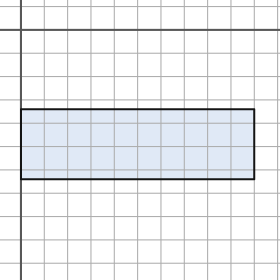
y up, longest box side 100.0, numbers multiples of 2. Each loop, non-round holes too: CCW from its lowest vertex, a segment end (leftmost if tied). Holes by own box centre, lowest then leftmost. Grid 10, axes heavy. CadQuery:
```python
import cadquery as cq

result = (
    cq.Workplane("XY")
    .moveTo(0.0, -64.0)
    .lineTo(100.0, -64.0)
    .lineTo(100.0, -34.0)
    .lineTo(0.0, -34.0)
    .close()
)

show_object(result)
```